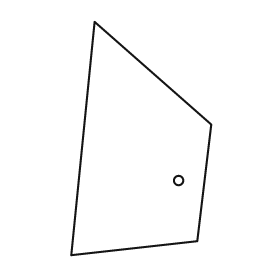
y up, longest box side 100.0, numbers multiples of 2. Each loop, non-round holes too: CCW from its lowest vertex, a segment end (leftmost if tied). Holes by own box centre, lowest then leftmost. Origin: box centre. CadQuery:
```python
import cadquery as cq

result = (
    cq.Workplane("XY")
    .moveTo(-30.0, -50.0)
    .lineTo(24.0, -44.0)
    .lineTo(30.0, 6.0)
    .lineTo(-20.0, 50.0)
    .close()
    .moveTo(16.0, -18.0)
    .circle(2.0)
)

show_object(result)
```